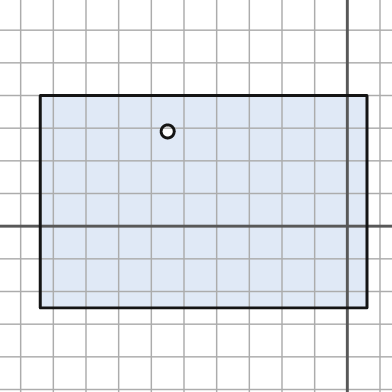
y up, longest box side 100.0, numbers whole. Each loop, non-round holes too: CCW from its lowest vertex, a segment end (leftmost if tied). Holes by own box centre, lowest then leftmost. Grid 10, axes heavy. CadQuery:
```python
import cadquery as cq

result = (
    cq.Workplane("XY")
    .moveTo(-94.0, -25.0)
    .lineTo(6.0, -25.0)
    .lineTo(6.0, 40.0)
    .lineTo(-94.0, 40.0)
    .close()
    .moveTo(-55.0, 29.0)
    .circle(2.0)
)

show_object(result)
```